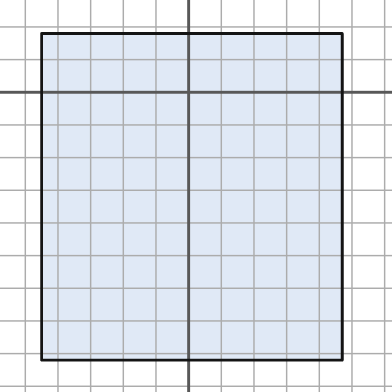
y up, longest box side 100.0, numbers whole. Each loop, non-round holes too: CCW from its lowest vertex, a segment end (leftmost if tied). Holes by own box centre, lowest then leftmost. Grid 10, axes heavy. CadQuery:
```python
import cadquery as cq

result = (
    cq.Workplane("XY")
    .moveTo(-45.0, -82.0)
    .lineTo(47.0, -82.0)
    .lineTo(47.0, 18.0)
    .lineTo(-45.0, 18.0)
    .close()
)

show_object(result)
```